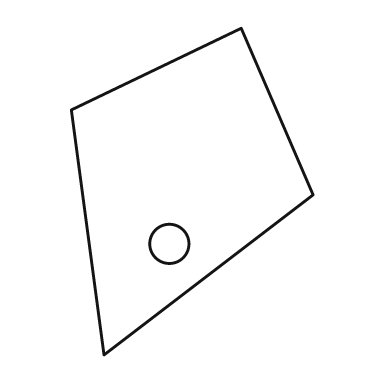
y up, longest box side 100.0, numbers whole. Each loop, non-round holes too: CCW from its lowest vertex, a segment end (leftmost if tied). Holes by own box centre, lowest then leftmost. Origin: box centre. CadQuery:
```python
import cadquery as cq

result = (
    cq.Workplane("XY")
    .moveTo(-27.0, -50.0)
    .lineTo(37.0, -1.0)
    .lineTo(15.0, 50.0)
    .lineTo(-37.0, 25.0)
    .close()
    .moveTo(-7.0, -16.0)
    .circle(6.0)
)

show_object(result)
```